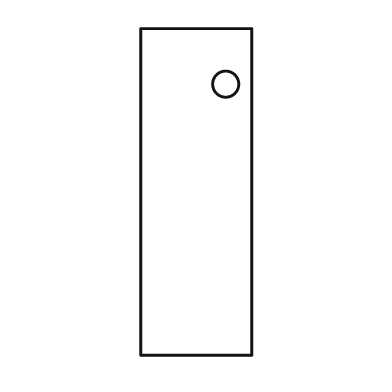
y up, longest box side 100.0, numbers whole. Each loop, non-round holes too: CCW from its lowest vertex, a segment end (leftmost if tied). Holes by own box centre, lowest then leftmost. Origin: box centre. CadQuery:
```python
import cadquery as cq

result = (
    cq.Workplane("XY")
    .moveTo(-17.0, -50.0)
    .lineTo(17.0, -50.0)
    .lineTo(17.0, 50.0)
    .lineTo(-17.0, 50.0)
    .close()
    .moveTo(9.0, 33.0)
    .circle(4.0)
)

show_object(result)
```